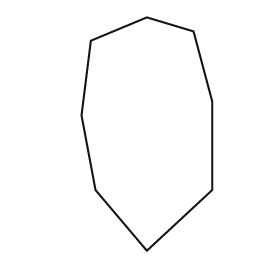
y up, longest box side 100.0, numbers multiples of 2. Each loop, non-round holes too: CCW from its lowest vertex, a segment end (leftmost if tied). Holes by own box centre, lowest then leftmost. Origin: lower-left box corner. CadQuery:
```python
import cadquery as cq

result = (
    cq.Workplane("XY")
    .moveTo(28.0, 0.0)
    .lineTo(56.0, 26.0)
    .lineTo(56.0, 64.0)
    .lineTo(48.0, 94.0)
    .lineTo(28.0, 100.0)
    .lineTo(4.0, 90.0)
    .lineTo(0.0, 58.0)
    .lineTo(6.0, 26.0)
    .close()
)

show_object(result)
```